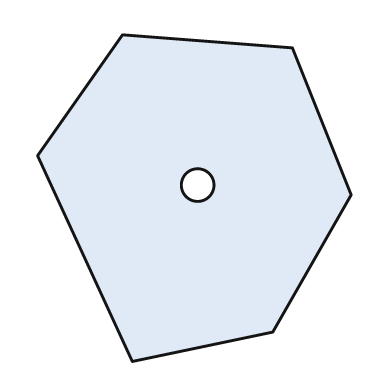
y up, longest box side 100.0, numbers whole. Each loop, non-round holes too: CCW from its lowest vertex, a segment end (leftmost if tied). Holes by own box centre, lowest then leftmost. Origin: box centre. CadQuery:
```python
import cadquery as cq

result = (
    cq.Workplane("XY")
    .moveTo(-19.0, -50.0)
    .lineTo(24.0, -41.0)
    .lineTo(48.0, 1.0)
    .lineTo(30.0, 46.0)
    .lineTo(-22.0, 50.0)
    .lineTo(-48.0, 13.0)
    .close()
    .moveTo(1.0, 4.0)
    .circle(5.0)
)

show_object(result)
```